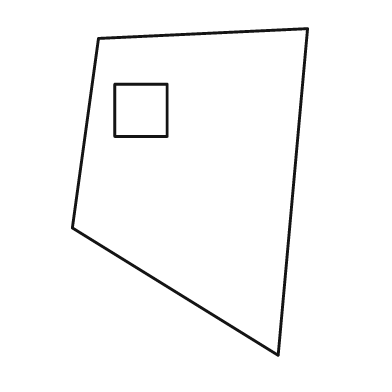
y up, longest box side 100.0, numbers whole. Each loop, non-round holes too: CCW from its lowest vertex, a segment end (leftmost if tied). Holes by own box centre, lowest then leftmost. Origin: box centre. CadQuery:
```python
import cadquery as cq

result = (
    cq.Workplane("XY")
    .moveTo(27.0, -50.0)
    .lineTo(36.0, 50.0)
    .lineTo(-28.0, 47.0)
    .lineTo(-36.0, -11.0)
    .close()
    .moveTo(-23.0, 17.0)
    .lineTo(-7.0, 17.0)
    .lineTo(-7.0, 33.0)
    .lineTo(-23.0, 33.0)
    .close()
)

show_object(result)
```